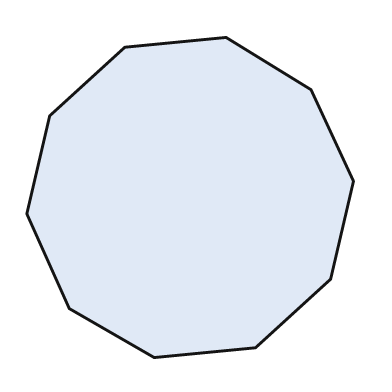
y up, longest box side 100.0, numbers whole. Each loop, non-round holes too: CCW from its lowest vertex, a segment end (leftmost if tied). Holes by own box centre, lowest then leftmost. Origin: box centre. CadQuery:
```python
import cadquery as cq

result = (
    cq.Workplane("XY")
    .moveTo(-11.0, -49.0)
    .lineTo(20.0, -46.0)
    .lineTo(43.0, -25.0)
    .lineTo(50.0, 5.0)
    .lineTo(37.0, 33.0)
    .lineTo(11.0, 49.0)
    .lineTo(-20.0, 46.0)
    .lineTo(-43.0, 25.0)
    .lineTo(-50.0, -5.0)
    .lineTo(-37.0, -34.0)
    .close()
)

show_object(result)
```